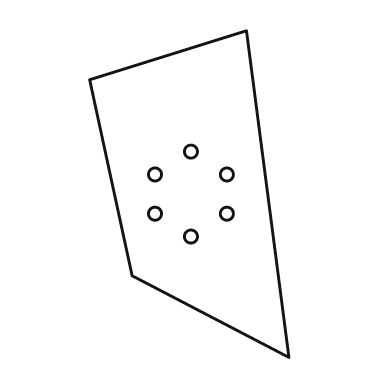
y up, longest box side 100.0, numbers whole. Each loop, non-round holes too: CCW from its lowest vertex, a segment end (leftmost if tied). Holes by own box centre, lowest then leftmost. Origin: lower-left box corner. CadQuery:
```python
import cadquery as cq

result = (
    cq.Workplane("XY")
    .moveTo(61.0, 0.0)
    .lineTo(48.0, 100.0)
    .lineTo(0.0, 85.0)
    .lineTo(13.0, 25.0)
    .close()
    .moveTo(31.0, 37.0)
    .circle(2.0)
    .moveTo(20.0, 44.0)
    .circle(2.0)
    .moveTo(42.0, 44.0)
    .circle(2.0)
    .moveTo(20.0, 56.0)
    .circle(2.0)
    .moveTo(42.0, 56.0)
    .circle(2.0)
    .moveTo(31.0, 63.0)
    .circle(2.0)
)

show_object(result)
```